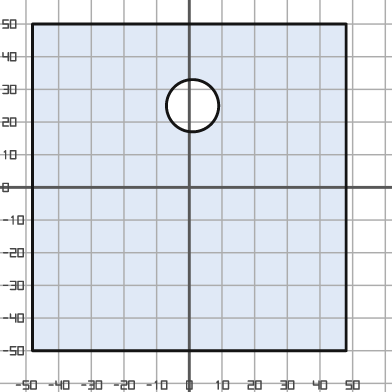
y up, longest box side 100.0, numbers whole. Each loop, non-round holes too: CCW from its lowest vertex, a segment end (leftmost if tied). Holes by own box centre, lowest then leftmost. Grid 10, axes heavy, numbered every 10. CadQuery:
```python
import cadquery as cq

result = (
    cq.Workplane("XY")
    .moveTo(-48.0, -50.0)
    .lineTo(48.0, -50.0)
    .lineTo(48.0, 50.0)
    .lineTo(-48.0, 50.0)
    .close()
    .moveTo(1.0, 25.0)
    .circle(8.0)
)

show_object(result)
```